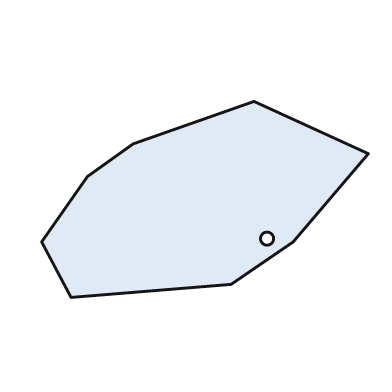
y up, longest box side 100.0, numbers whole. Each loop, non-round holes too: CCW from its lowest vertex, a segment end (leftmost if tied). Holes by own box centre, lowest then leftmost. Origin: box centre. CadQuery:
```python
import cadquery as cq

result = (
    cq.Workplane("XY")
    .moveTo(-41.0, -30.0)
    .lineTo(8.0, -26.0)
    .lineTo(27.0, -13.0)
    .lineTo(50.0, 14.0)
    .lineTo(15.0, 30.0)
    .lineTo(-22.0, 17.0)
    .lineTo(-36.0, 7.0)
    .lineTo(-50.0, -13.0)
    .close()
    .moveTo(19.0, -12.0)
    .circle(2.0)
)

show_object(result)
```